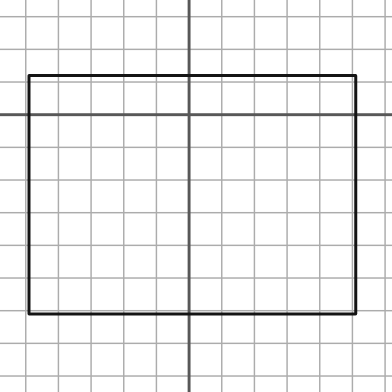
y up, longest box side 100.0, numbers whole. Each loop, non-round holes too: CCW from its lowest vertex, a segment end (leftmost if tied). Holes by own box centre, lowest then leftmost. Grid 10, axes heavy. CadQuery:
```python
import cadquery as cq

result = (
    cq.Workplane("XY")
    .moveTo(-49.0, -61.0)
    .lineTo(51.0, -61.0)
    .lineTo(51.0, 12.0)
    .lineTo(-49.0, 12.0)
    .close()
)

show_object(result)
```